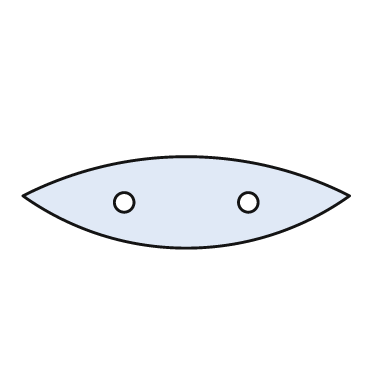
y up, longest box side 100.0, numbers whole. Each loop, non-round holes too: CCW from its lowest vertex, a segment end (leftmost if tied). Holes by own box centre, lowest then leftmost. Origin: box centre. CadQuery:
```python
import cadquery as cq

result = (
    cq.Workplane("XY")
    .moveTo(-50.0, 2.0)
    .threePointArc((0.0, -14.0), (50.0, 2.0))
    .threePointArc((0.0, 14.0), (-50.0, 2.0))
    .close()
    .moveTo(-19.0, 0.0)
    .circle(3.0)
    .moveTo(19.0, 0.0)
    .circle(3.0)
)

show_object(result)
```